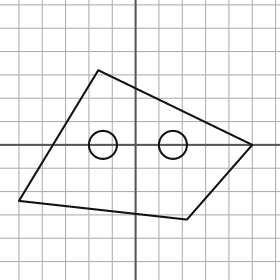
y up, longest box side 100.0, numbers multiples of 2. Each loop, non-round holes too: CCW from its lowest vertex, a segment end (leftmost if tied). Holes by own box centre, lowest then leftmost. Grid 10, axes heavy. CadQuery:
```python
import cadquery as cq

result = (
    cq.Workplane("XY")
    .moveTo(22.0, -32.0)
    .lineTo(50.0, 0.0)
    .lineTo(-16.0, 32.0)
    .lineTo(-50.0, -24.0)
    .close()
    .moveTo(-14.0, 0.0)
    .circle(6.0)
    .moveTo(16.0, 0.0)
    .circle(6.0)
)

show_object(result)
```